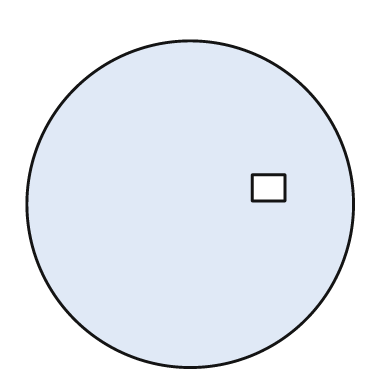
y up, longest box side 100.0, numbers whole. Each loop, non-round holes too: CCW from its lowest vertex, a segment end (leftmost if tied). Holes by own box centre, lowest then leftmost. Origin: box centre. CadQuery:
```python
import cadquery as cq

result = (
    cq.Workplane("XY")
    .moveTo(0.0, 0.0)
    .circle(50.0)
    .moveTo(19.0, 1.0)
    .lineTo(29.0, 1.0)
    .lineTo(29.0, 9.0)
    .lineTo(19.0, 9.0)
    .close()
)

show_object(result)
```